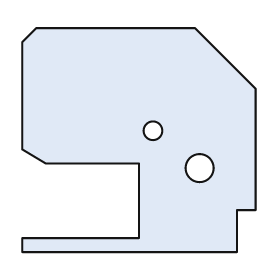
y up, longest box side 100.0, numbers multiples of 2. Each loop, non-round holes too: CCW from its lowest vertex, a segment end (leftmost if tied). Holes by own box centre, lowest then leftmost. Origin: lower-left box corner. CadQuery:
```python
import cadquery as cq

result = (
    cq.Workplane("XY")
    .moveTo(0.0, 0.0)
    .lineTo(92.0, 0.0)
    .lineTo(92.0, 18.0)
    .lineTo(100.0, 18.0)
    .lineTo(100.0, 70.0)
    .lineTo(74.0, 96.0)
    .lineTo(6.0, 96.0)
    .lineTo(0.0, 90.0)
    .lineTo(0.0, 44.0)
    .lineTo(10.0, 38.0)
    .lineTo(50.0, 38.0)
    .lineTo(50.0, 6.0)
    .lineTo(0.0, 6.0)
    .close()
    .moveTo(76.0, 36.0)
    .circle(6.0)
    .moveTo(56.0, 52.0)
    .circle(4.0)
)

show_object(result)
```